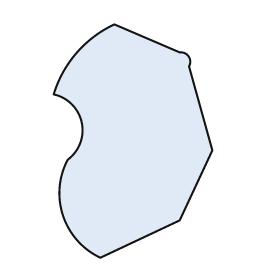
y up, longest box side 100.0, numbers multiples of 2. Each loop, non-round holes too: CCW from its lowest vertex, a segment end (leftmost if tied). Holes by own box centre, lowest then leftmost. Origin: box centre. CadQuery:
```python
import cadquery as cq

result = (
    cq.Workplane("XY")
    .moveTo(-14.0, -50.0)
    .lineTo(20.0, -34.0)
    .lineTo(34.0, -4.0)
    .lineTo(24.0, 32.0)
    .threePointArc((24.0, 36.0), (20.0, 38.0))
    .lineTo(-8.0, 50.0)
    .threePointArc((-24.0, 38.0), (-34.0, 20.0))
    .threePointArc((-22.0, 8.0), (-28.0, -8.0))
    .threePointArc((-30.0, -32.0), (-14.0, -50.0))
    .close()
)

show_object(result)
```